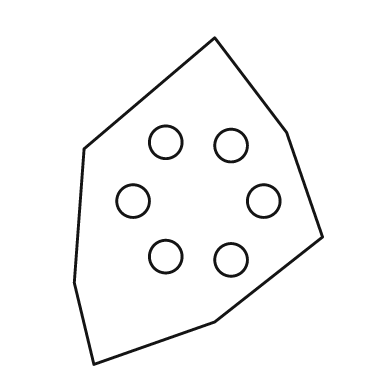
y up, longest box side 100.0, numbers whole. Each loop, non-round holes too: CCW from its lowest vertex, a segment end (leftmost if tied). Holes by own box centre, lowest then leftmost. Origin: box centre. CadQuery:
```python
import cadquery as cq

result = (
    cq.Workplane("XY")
    .moveTo(-32.0, -50.0)
    .lineTo(5.0, -37.0)
    .lineTo(38.0, -11.0)
    .lineTo(27.0, 21.0)
    .lineTo(5.0, 50.0)
    .lineTo(-35.0, 16.0)
    .lineTo(-38.0, -25.0)
    .close()
    .moveTo(10.0, -18.0)
    .circle(5.0)
    .moveTo(-10.0, -17.0)
    .circle(5.0)
    .moveTo(-20.0, 0.0)
    .circle(5.0)
    .moveTo(20.0, 0.0)
    .circle(5.0)
    .moveTo(10.0, 17.0)
    .circle(5.0)
    .moveTo(-10.0, 18.0)
    .circle(5.0)
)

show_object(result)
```